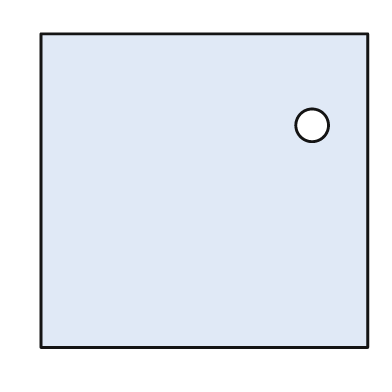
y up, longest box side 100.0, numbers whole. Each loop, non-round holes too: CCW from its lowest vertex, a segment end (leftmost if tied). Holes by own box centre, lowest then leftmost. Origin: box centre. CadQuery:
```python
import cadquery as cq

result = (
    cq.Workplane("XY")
    .moveTo(-50.0, -48.0)
    .lineTo(50.0, -48.0)
    .lineTo(50.0, 48.0)
    .lineTo(-50.0, 48.0)
    .close()
    .moveTo(33.0, 20.0)
    .circle(5.0)
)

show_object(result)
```